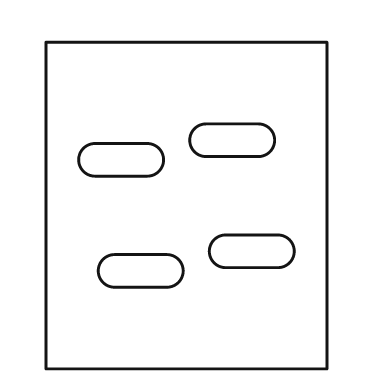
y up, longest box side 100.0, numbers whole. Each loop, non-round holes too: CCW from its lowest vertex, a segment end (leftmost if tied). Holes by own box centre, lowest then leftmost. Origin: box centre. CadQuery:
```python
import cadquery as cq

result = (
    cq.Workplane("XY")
    .moveTo(-43.0, -50.0)
    .lineTo(43.0, -50.0)
    .lineTo(43.0, 50.0)
    .lineTo(-43.0, 50.0)
    .close()
    .moveTo(-22.0, -25.0)
    .lineTo(-6.0, -25.0)
    .threePointArc((-1.0, -20.0), (-6.0, -15.0))
    .lineTo(-22.0, -15.0)
    .threePointArc((-27.0, -20.0), (-22.0, -25.0))
    .close()
    .moveTo(12.0, -19.0)
    .lineTo(28.0, -19.0)
    .threePointArc((33.0, -14.0), (28.0, -9.0))
    .lineTo(12.0, -9.0)
    .threePointArc((7.0, -14.0), (12.0, -19.0))
    .close()
    .moveTo(-28.0, 9.0)
    .lineTo(-12.0, 9.0)
    .threePointArc((-7.0, 14.0), (-12.0, 19.0))
    .lineTo(-28.0, 19.0)
    .threePointArc((-33.0, 14.0), (-28.0, 9.0))
    .close()
    .moveTo(6.0, 15.0)
    .lineTo(22.0, 15.0)
    .threePointArc((27.0, 20.0), (22.0, 25.0))
    .lineTo(6.0, 25.0)
    .threePointArc((1.0, 20.0), (6.0, 15.0))
    .close()
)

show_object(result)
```